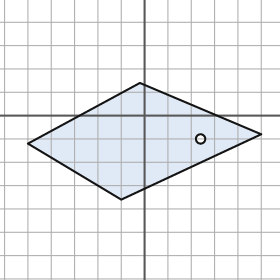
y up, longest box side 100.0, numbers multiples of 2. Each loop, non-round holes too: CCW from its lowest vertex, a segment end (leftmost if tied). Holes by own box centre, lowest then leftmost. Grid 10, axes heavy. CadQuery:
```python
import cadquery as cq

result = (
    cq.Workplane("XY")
    .moveTo(-10.0, -36.0)
    .lineTo(50.0, -8.0)
    .lineTo(-2.0, 14.0)
    .lineTo(-50.0, -12.0)
    .close()
    .moveTo(24.0, -10.0)
    .circle(2.0)
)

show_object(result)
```